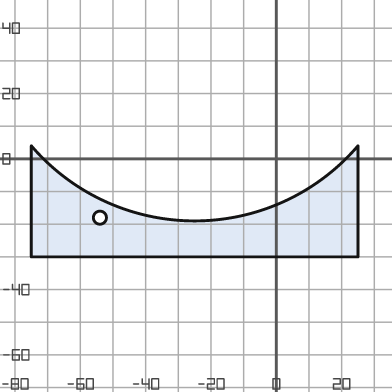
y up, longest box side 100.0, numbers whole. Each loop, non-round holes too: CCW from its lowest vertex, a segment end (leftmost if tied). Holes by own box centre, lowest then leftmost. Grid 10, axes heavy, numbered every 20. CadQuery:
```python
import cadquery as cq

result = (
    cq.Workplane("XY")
    .moveTo(-75.0, -30.0)
    .lineTo(25.0, -30.0)
    .lineTo(25.0, 4.0)
    .threePointArc((-25.0, -19.0), (-75.0, 4.0))
    .close()
    .moveTo(-54.0, -18.0)
    .circle(2.0)
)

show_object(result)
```